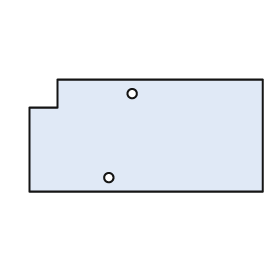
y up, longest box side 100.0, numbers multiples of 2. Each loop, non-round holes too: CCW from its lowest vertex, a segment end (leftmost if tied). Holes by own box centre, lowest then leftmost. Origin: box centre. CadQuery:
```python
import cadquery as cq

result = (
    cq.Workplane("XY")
    .moveTo(-50.0, -24.0)
    .lineTo(50.0, -24.0)
    .lineTo(50.0, 24.0)
    .lineTo(-38.0, 24.0)
    .lineTo(-38.0, 12.0)
    .lineTo(-50.0, 12.0)
    .close()
    .moveTo(-16.0, -18.0)
    .circle(2.0)
    .moveTo(-6.0, 18.0)
    .circle(2.0)
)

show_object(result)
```